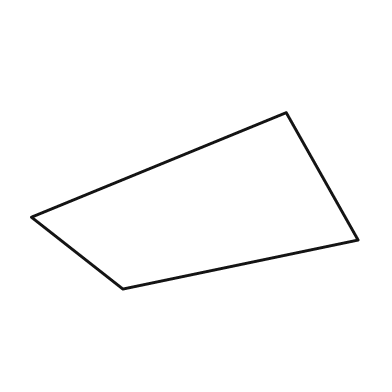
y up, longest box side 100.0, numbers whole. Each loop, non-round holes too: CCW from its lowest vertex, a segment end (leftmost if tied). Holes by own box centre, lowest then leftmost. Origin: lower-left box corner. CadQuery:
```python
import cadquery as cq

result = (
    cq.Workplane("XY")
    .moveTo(28.0, 0.0)
    .lineTo(100.0, 15.0)
    .lineTo(78.0, 54.0)
    .lineTo(0.0, 22.0)
    .close()
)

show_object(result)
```